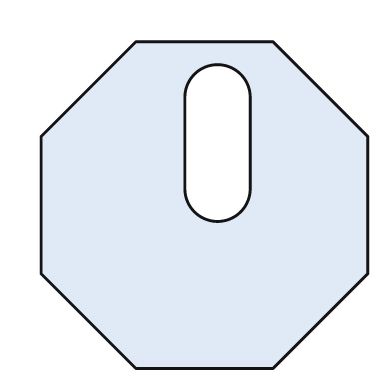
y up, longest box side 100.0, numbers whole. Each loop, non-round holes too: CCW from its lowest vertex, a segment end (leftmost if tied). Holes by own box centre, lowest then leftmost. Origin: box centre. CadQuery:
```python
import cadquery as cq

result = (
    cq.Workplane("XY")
    .moveTo(-21.0, -50.0)
    .lineTo(21.0, -50.0)
    .lineTo(50.0, -21.0)
    .lineTo(50.0, 21.0)
    .lineTo(21.0, 50.0)
    .lineTo(-21.0, 50.0)
    .lineTo(-50.0, 21.0)
    .lineTo(-50.0, -21.0)
    .close()
    .moveTo(-6.0, 5.0)
    .threePointArc((4.0, -5.0), (14.0, 5.0))
    .lineTo(14.0, 33.0)
    .threePointArc((4.0, 43.0), (-6.0, 33.0))
    .close()
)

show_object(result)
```